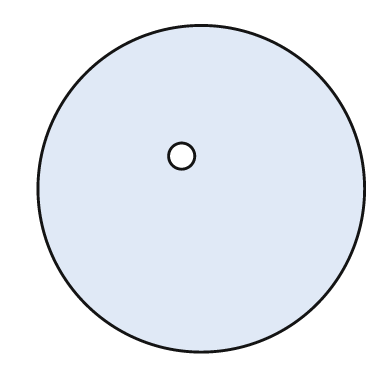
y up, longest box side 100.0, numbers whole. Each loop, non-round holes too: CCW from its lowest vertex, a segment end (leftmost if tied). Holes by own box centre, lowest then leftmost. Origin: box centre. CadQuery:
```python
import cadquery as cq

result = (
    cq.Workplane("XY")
    .moveTo(0.0, 0.0)
    .circle(50.0)
    .moveTo(-6.0, 10.0)
    .circle(4.0)
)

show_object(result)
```